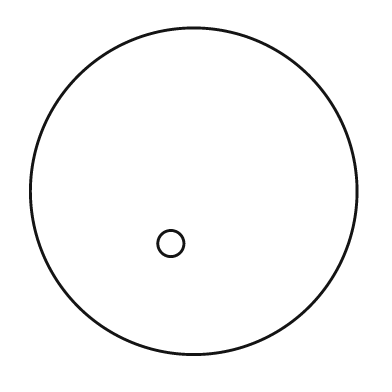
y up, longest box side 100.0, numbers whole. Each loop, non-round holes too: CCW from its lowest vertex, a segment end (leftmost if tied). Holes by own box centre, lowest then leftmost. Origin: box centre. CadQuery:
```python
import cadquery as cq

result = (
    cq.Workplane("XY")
    .moveTo(0.0, 0.0)
    .circle(50.0)
    .moveTo(-7.0, -16.0)
    .circle(4.0)
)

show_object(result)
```